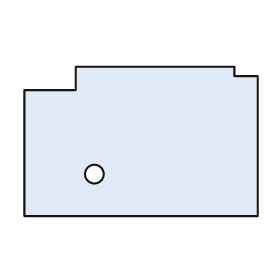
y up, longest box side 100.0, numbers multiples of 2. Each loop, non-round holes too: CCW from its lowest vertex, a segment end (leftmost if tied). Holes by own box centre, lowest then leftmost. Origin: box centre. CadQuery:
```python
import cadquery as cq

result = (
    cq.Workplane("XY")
    .moveTo(-50.0, -32.0)
    .lineTo(50.0, -32.0)
    .lineTo(50.0, 28.0)
    .lineTo(40.0, 28.0)
    .lineTo(40.0, 32.0)
    .lineTo(-28.0, 32.0)
    .lineTo(-28.0, 22.0)
    .lineTo(-50.0, 22.0)
    .close()
    .moveTo(-20.0, -14.0)
    .circle(4.0)
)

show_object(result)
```